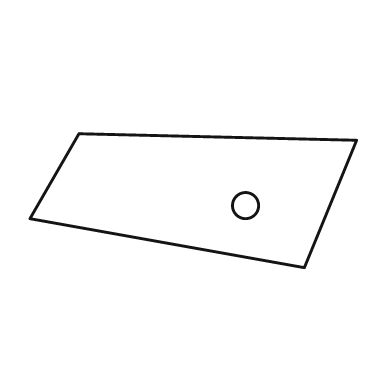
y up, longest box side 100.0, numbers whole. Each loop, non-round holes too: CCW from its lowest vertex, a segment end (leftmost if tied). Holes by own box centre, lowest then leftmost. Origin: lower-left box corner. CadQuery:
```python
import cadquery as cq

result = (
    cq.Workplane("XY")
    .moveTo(84.0, 0.0)
    .lineTo(100.0, 39.0)
    .lineTo(15.0, 41.0)
    .lineTo(0.0, 15.0)
    .close()
    .moveTo(66.0, 19.0)
    .circle(4.0)
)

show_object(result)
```